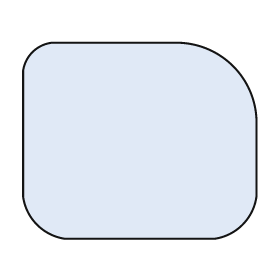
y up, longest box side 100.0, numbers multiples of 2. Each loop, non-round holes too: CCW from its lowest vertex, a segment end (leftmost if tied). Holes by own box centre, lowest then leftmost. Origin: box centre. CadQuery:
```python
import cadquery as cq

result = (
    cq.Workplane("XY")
    .moveTo(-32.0, -42.0)
    .lineTo(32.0, -42.0)
    .threePointArc((44.0, -36.0), (50.0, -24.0))
    .lineTo(50.0, 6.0)
    .threePointArc((40.0, 32.0), (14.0, 42.0))
    .lineTo(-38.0, 42.0)
    .threePointArc((-46.0, 38.0), (-50.0, 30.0))
    .lineTo(-50.0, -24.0)
    .threePointArc((-44.0, -36.0), (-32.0, -42.0))
    .close()
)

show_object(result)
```